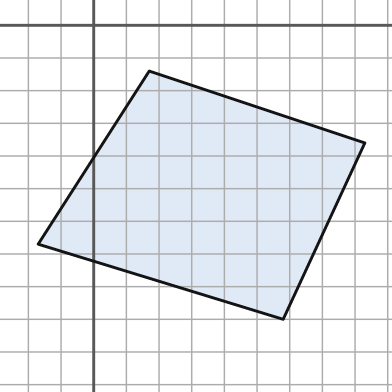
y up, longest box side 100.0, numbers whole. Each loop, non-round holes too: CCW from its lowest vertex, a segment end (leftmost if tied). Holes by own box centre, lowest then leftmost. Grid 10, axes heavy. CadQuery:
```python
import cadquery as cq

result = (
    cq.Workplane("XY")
    .moveTo(58.0, -90.0)
    .lineTo(83.0, -36.0)
    .lineTo(17.0, -14.0)
    .lineTo(-17.0, -67.0)
    .close()
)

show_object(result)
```